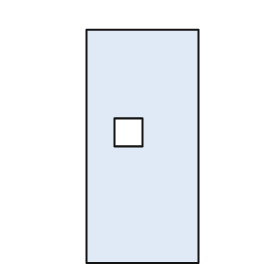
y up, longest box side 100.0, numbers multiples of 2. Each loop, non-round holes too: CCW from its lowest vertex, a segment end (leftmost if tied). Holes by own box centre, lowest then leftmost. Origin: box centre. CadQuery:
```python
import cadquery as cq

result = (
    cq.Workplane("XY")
    .moveTo(-24.0, -50.0)
    .lineTo(24.0, -50.0)
    .lineTo(24.0, 50.0)
    .lineTo(-24.0, 50.0)
    .close()
    .moveTo(-12.0, 0.0)
    .lineTo(0.0, 0.0)
    .lineTo(0.0, 12.0)
    .lineTo(-12.0, 12.0)
    .close()
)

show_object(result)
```